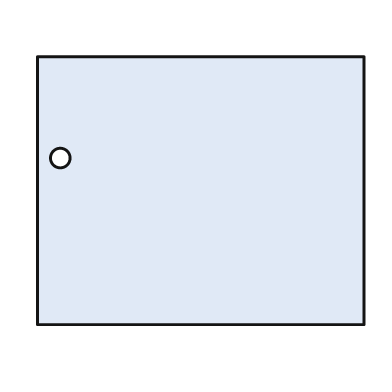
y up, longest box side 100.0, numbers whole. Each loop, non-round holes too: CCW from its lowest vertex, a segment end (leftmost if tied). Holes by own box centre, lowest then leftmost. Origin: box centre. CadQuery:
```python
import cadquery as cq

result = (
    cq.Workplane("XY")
    .moveTo(-50.0, -41.0)
    .lineTo(50.0, -41.0)
    .lineTo(50.0, 41.0)
    .lineTo(-50.0, 41.0)
    .close()
    .moveTo(-43.0, 10.0)
    .circle(3.0)
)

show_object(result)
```